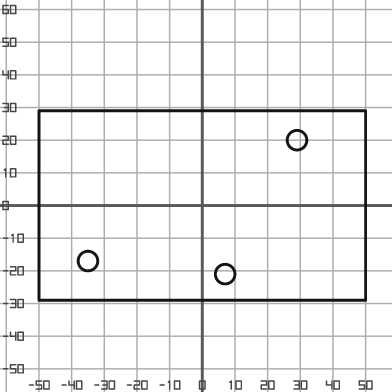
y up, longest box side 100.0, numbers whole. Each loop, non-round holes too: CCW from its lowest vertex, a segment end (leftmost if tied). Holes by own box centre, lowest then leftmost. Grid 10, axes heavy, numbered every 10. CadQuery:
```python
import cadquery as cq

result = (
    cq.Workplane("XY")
    .moveTo(-50.0, -29.0)
    .lineTo(50.0, -29.0)
    .lineTo(50.0, 29.0)
    .lineTo(-50.0, 29.0)
    .close()
    .moveTo(7.0, -21.0)
    .circle(3.0)
    .moveTo(-35.0, -17.0)
    .circle(3.0)
    .moveTo(29.0, 20.0)
    .circle(3.0)
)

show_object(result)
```